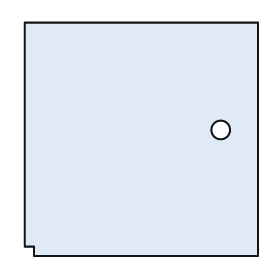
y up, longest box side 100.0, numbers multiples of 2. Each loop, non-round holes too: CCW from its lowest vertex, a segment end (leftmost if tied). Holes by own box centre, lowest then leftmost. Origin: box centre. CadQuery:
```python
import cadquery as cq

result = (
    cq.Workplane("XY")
    .moveTo(-46.0, -50.0)
    .lineTo(50.0, -50.0)
    .lineTo(50.0, 50.0)
    .lineTo(-50.0, 50.0)
    .lineTo(-50.0, -46.0)
    .lineTo(-46.0, -46.0)
    .close()
    .moveTo(34.0, 4.0)
    .circle(4.0)
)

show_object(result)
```